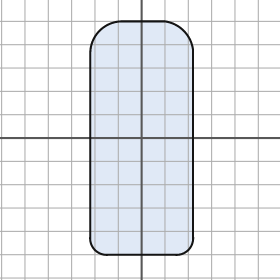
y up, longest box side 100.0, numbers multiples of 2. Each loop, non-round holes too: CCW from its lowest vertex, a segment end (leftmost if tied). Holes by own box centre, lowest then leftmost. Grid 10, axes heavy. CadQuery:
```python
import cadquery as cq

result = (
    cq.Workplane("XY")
    .moveTo(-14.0, -50.0)
    .lineTo(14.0, -50.0)
    .threePointArc((20.0, -48.0), (22.0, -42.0))
    .lineTo(22.0, 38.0)
    .threePointArc((18.0, 46.0), (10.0, 50.0))
    .lineTo(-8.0, 50.0)
    .threePointArc((-18.0, 46.0), (-22.0, 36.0))
    .lineTo(-22.0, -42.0)
    .threePointArc((-20.0, -48.0), (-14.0, -50.0))
    .close()
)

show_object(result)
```